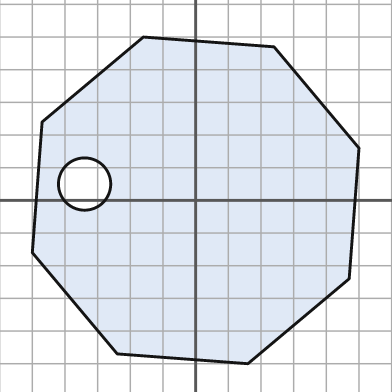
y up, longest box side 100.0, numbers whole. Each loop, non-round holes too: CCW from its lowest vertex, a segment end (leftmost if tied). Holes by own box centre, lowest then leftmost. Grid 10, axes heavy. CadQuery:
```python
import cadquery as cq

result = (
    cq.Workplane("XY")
    .moveTo(16.0, -50.0)
    .lineTo(47.0, -24.0)
    .lineTo(50.0, 16.0)
    .lineTo(24.0, 47.0)
    .lineTo(-16.0, 50.0)
    .lineTo(-47.0, 24.0)
    .lineTo(-50.0, -16.0)
    .lineTo(-24.0, -47.0)
    .close()
    .moveTo(-34.0, 5.0)
    .circle(8.0)
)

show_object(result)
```